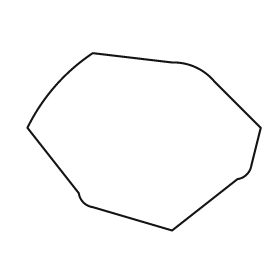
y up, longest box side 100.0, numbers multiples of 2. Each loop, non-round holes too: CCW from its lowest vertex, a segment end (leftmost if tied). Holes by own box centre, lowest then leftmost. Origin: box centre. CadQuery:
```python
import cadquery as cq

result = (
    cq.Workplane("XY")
    .moveTo(12.0, -38.0)
    .lineTo(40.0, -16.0)
    .threePointArc((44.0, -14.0), (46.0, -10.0))
    .lineTo(50.0, 6.0)
    .lineTo(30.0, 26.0)
    .threePointArc((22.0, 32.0), (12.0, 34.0))
    .lineTo(-22.0, 38.0)
    .threePointArc((-38.0, 24.0), (-50.0, 6.0))
    .lineTo(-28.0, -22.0)
    .threePointArc((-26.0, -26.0), (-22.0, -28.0))
    .close()
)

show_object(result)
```